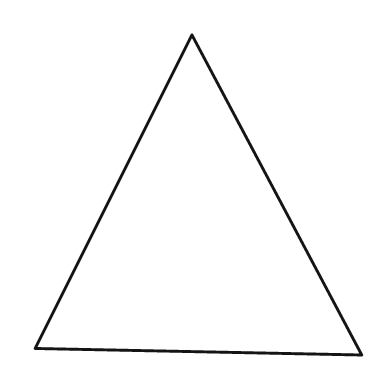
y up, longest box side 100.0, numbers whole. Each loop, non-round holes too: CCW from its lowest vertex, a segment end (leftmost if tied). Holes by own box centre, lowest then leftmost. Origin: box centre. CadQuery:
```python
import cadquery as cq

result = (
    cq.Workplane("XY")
    .moveTo(50.0, -49.0)
    .lineTo(-2.0, 49.0)
    .lineTo(-50.0, -47.0)
    .close()
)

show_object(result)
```